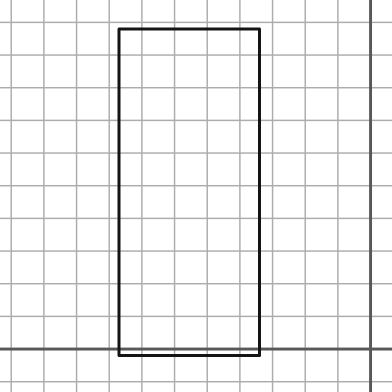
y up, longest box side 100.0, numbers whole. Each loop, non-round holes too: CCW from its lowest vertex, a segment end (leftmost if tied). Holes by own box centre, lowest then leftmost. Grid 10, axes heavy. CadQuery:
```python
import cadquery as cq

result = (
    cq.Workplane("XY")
    .moveTo(-77.0, -2.0)
    .lineTo(-34.0, -2.0)
    .lineTo(-34.0, 98.0)
    .lineTo(-77.0, 98.0)
    .close()
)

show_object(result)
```